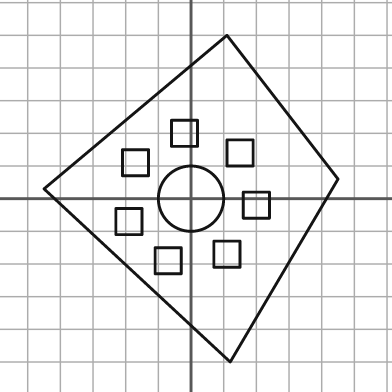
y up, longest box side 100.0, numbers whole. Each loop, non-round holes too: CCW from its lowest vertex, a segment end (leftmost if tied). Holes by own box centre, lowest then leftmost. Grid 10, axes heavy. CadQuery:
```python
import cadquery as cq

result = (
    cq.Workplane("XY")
    .moveTo(12.0, -50.0)
    .lineTo(45.0, 6.0)
    .lineTo(11.0, 50.0)
    .lineTo(-45.0, 3.0)
    .close()
    .moveTo(-11.0, -23.0)
    .lineTo(-3.0, -23.0)
    .lineTo(-3.0, -15.0)
    .lineTo(-11.0, -15.0)
    .close()
    .moveTo(7.0, -21.0)
    .lineTo(15.0, -21.0)
    .lineTo(15.0, -13.0)
    .lineTo(7.0, -13.0)
    .close()
    .moveTo(-23.0, -11.0)
    .lineTo(-15.0, -11.0)
    .lineTo(-15.0, -3.0)
    .lineTo(-23.0, -3.0)
    .close()
    .moveTo(16.0, -6.0)
    .lineTo(24.0, -6.0)
    .lineTo(24.0, 2.0)
    .lineTo(16.0, 2.0)
    .close()
    .moveTo(0.0, 0.0)
    .circle(10.0)
    .moveTo(-21.0, 7.0)
    .lineTo(-13.0, 7.0)
    .lineTo(-13.0, 15.0)
    .lineTo(-21.0, 15.0)
    .close()
    .moveTo(11.0, 10.0)
    .lineTo(19.0, 10.0)
    .lineTo(19.0, 18.0)
    .lineTo(11.0, 18.0)
    .close()
    .moveTo(-6.0, 16.0)
    .lineTo(2.0, 16.0)
    .lineTo(2.0, 24.0)
    .lineTo(-6.0, 24.0)
    .close()
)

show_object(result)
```